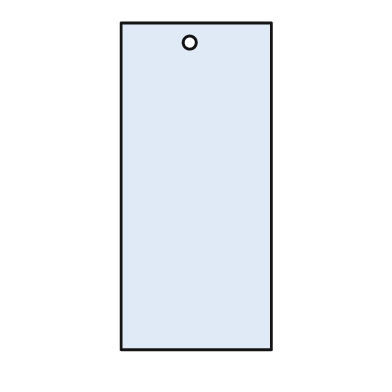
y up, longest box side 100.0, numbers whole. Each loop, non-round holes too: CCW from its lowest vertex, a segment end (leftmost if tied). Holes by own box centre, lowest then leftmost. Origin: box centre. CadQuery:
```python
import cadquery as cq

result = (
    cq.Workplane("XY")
    .moveTo(-23.0, -50.0)
    .lineTo(23.0, -50.0)
    .lineTo(23.0, 50.0)
    .lineTo(-23.0, 50.0)
    .close()
    .moveTo(-2.0, 44.0)
    .circle(2.0)
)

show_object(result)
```